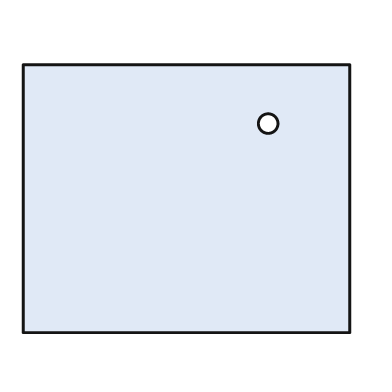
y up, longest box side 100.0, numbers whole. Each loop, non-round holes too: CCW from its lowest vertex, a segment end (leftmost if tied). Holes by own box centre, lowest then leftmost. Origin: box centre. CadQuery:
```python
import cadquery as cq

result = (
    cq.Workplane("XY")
    .moveTo(-50.0, -41.0)
    .lineTo(50.0, -41.0)
    .lineTo(50.0, 41.0)
    .lineTo(-50.0, 41.0)
    .close()
    .moveTo(25.0, 23.0)
    .circle(3.0)
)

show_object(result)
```